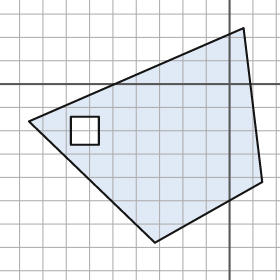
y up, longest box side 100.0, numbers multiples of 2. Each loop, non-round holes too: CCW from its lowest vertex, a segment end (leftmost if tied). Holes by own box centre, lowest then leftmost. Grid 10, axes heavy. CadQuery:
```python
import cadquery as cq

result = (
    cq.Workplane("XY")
    .moveTo(-32.0, -68.0)
    .lineTo(14.0, -42.0)
    .lineTo(6.0, 24.0)
    .lineTo(-86.0, -16.0)
    .close()
    .moveTo(-68.0, -26.0)
    .lineTo(-56.0, -26.0)
    .lineTo(-56.0, -14.0)
    .lineTo(-68.0, -14.0)
    .close()
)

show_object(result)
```